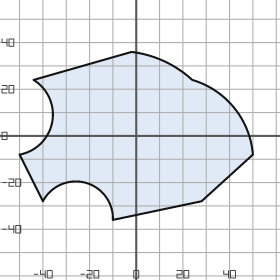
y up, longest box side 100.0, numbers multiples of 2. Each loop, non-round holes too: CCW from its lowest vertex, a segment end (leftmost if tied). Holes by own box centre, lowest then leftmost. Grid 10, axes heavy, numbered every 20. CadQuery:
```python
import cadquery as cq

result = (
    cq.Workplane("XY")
    .moveTo(-10.0, -36.0)
    .lineTo(28.0, -28.0)
    .lineTo(50.0, -8.0)
    .threePointArc((42.0, 12.0), (24.0, 24.0))
    .threePointArc((12.0, 32.0), (-2.0, 36.0))
    .lineTo(-44.0, 24.0)
    .threePointArc((-36.0, 6.0), (-50.0, -8.0))
    .lineTo(-40.0, -28.0)
    .threePointArc((-22.0, -20.0), (-10.0, -36.0))
    .close()
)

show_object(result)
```